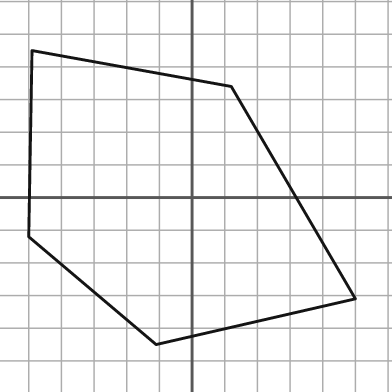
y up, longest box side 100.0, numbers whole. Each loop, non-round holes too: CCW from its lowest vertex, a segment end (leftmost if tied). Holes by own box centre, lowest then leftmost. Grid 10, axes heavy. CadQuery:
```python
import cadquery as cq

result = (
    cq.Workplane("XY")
    .moveTo(-11.0, -45.0)
    .lineTo(50.0, -31.0)
    .lineTo(12.0, 34.0)
    .lineTo(-49.0, 45.0)
    .lineTo(-50.0, -12.0)
    .close()
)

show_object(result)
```